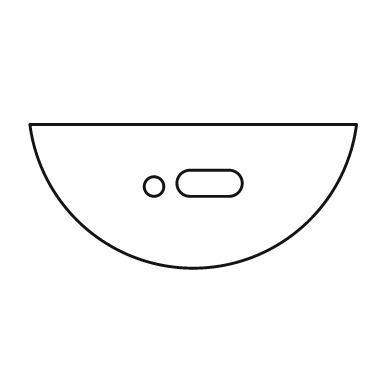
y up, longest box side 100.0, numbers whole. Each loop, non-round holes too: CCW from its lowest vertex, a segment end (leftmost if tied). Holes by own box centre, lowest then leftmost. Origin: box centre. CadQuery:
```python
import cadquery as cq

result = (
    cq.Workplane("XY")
    .moveTo(-50.0, 22.0)
    .threePointArc((0.0, -22.0), (50.0, 22.0))
    .close()
    .moveTo(-12.0, 3.0)
    .circle(3.0)
    .moveTo(-1.0, 0.0)
    .lineTo(11.0, 0.0)
    .threePointArc((15.0, 4.0), (11.0, 8.0))
    .lineTo(-1.0, 8.0)
    .threePointArc((-5.0, 4.0), (-1.0, 0.0))
    .close()
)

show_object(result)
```